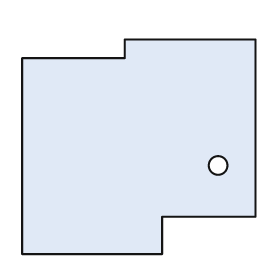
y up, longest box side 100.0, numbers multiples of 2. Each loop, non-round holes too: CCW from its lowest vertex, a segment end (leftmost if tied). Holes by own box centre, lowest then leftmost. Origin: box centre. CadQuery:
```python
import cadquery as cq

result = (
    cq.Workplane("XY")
    .moveTo(-50.0, -46.0)
    .lineTo(10.0, -46.0)
    .lineTo(10.0, -30.0)
    .lineTo(50.0, -30.0)
    .lineTo(50.0, 46.0)
    .lineTo(-6.0, 46.0)
    .lineTo(-6.0, 38.0)
    .lineTo(-50.0, 38.0)
    .close()
    .moveTo(34.0, -8.0)
    .circle(4.0)
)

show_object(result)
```